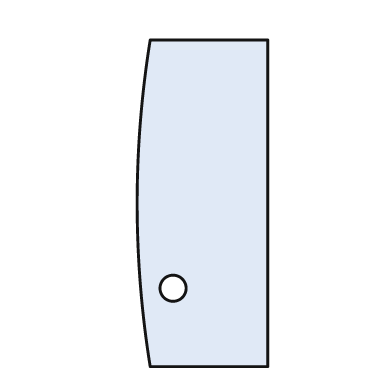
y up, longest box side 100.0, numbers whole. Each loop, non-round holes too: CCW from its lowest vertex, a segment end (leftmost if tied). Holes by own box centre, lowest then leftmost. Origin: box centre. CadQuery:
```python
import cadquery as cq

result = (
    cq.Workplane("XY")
    .moveTo(-16.0, -50.0)
    .lineTo(20.0, -50.0)
    .lineTo(20.0, 50.0)
    .lineTo(-16.0, 50.0)
    .threePointArc((-20.0, 0.0), (-16.0, -50.0))
    .close()
    .moveTo(-9.0, -26.0)
    .circle(4.0)
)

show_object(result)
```